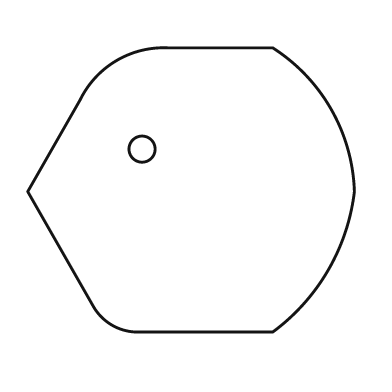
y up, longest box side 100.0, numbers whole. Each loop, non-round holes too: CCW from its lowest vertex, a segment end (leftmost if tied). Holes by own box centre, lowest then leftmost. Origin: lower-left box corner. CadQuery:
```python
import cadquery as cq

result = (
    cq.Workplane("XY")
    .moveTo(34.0, 0.0)
    .lineTo(75.0, 0.0)
    .threePointArc((92.0, 19.0), (100.0, 43.0))
    .threePointArc((93.0, 68.0), (75.0, 87.0))
    .lineTo(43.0, 87.0)
    .threePointArc((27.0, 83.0), (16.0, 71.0))
    .lineTo(0.0, 43.0)
    .lineTo(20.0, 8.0)
    .threePointArc((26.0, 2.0), (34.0, 0.0))
    .close()
    .moveTo(35.0, 56.0)
    .circle(4.0)
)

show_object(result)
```